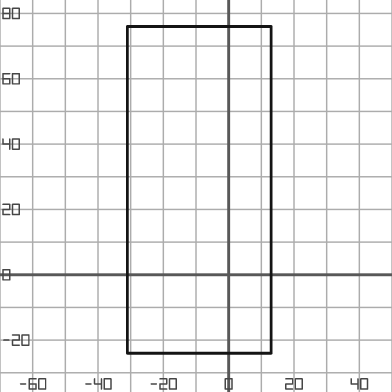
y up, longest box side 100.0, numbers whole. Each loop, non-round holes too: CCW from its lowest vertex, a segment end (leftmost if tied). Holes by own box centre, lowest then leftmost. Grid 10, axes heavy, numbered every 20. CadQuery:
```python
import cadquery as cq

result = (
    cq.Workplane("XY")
    .moveTo(-31.0, -24.0)
    .lineTo(13.0, -24.0)
    .lineTo(13.0, 76.0)
    .lineTo(-31.0, 76.0)
    .close()
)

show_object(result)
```